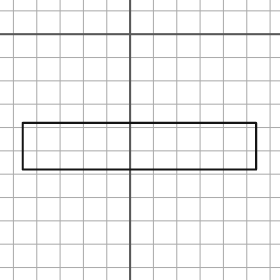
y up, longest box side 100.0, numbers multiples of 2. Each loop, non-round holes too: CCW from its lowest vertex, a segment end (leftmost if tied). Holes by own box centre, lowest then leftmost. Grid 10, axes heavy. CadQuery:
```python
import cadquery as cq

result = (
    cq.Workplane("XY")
    .moveTo(-46.0, -58.0)
    .lineTo(54.0, -58.0)
    .lineTo(54.0, -38.0)
    .lineTo(-46.0, -38.0)
    .close()
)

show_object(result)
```